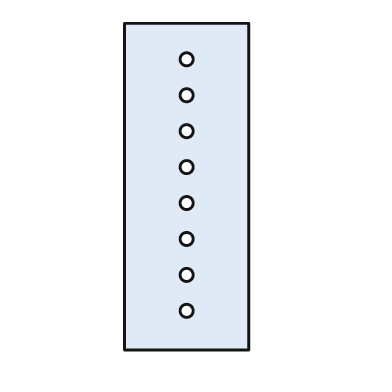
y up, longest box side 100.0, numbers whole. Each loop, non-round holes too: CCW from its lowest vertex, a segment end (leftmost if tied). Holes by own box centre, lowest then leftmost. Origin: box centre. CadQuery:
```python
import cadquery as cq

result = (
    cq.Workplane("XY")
    .moveTo(-19.0, -50.0)
    .lineTo(19.0, -50.0)
    .lineTo(19.0, 50.0)
    .lineTo(-19.0, 50.0)
    .close()
    .moveTo(0.0, -38.0)
    .circle(2.0)
    .moveTo(0.0, -27.0)
    .circle(2.0)
    .moveTo(0.0, -16.0)
    .circle(2.0)
    .moveTo(0.0, -5.0)
    .circle(2.0)
    .moveTo(0.0, 6.0)
    .circle(2.0)
    .moveTo(0.0, 17.0)
    .circle(2.0)
    .moveTo(0.0, 28.0)
    .circle(2.0)
    .moveTo(0.0, 39.0)
    .circle(2.0)
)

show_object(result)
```